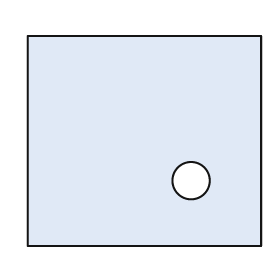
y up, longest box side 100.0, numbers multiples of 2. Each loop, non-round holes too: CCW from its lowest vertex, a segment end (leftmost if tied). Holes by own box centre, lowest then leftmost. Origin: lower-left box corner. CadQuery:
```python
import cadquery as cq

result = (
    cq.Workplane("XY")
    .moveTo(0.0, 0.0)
    .lineTo(100.0, 0.0)
    .lineTo(100.0, 90.0)
    .lineTo(0.0, 90.0)
    .close()
    .moveTo(70.0, 28.0)
    .circle(8.0)
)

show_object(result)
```